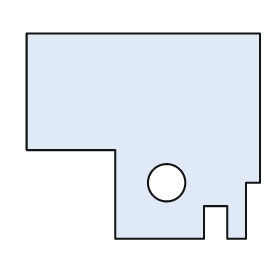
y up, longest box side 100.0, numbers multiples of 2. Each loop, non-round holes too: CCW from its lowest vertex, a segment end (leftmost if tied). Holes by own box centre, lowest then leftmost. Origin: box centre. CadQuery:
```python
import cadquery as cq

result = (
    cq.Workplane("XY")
    .moveTo(-12.0, -44.0)
    .lineTo(26.0, -44.0)
    .lineTo(26.0, -30.0)
    .lineTo(36.0, -30.0)
    .lineTo(36.0, -44.0)
    .lineTo(44.0, -44.0)
    .lineTo(44.0, -20.0)
    .lineTo(50.0, -20.0)
    .lineTo(50.0, 44.0)
    .lineTo(-50.0, 44.0)
    .lineTo(-50.0, -6.0)
    .lineTo(-12.0, -6.0)
    .close()
    .moveTo(10.0, -20.0)
    .circle(8.0)
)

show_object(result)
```